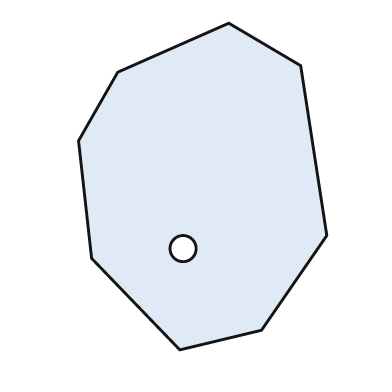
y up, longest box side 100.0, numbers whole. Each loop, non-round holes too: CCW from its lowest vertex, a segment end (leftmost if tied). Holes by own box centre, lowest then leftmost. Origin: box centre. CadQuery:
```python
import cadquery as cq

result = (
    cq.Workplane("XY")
    .moveTo(-7.0, -50.0)
    .lineTo(18.0, -44.0)
    .lineTo(38.0, -15.0)
    .lineTo(30.0, 37.0)
    .lineTo(8.0, 50.0)
    .lineTo(-26.0, 35.0)
    .lineTo(-38.0, 14.0)
    .lineTo(-34.0, -22.0)
    .close()
    .moveTo(-6.0, -19.0)
    .circle(4.0)
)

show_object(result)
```